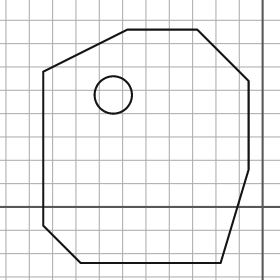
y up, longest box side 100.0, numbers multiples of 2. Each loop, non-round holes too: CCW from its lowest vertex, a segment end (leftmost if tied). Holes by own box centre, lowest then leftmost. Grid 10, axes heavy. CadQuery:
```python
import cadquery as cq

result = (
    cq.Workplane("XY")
    .moveTo(-78.0, -24.0)
    .lineTo(-18.0, -24.0)
    .lineTo(-6.0, 16.0)
    .lineTo(-6.0, 54.0)
    .lineTo(-28.0, 76.0)
    .lineTo(-58.0, 76.0)
    .lineTo(-94.0, 58.0)
    .lineTo(-94.0, -8.0)
    .close()
    .moveTo(-64.0, 48.0)
    .circle(8.0)
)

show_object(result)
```